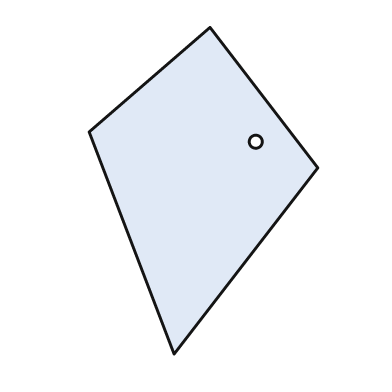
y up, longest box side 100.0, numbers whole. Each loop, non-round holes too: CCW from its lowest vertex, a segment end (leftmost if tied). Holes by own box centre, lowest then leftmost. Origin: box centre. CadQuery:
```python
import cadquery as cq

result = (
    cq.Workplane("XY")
    .moveTo(-9.0, -50.0)
    .lineTo(35.0, 7.0)
    .lineTo(2.0, 50.0)
    .lineTo(-35.0, 18.0)
    .close()
    .moveTo(16.0, 15.0)
    .circle(2.0)
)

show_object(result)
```